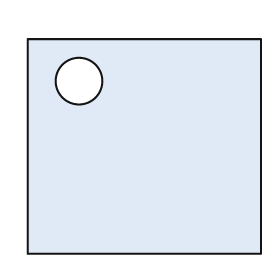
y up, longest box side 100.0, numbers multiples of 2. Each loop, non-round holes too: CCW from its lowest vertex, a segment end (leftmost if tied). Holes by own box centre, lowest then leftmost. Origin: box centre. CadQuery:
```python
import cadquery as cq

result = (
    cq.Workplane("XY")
    .moveTo(-50.0, -46.0)
    .lineTo(50.0, -46.0)
    .lineTo(50.0, 46.0)
    .lineTo(-50.0, 46.0)
    .close()
    .moveTo(-28.0, 28.0)
    .circle(10.0)
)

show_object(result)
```